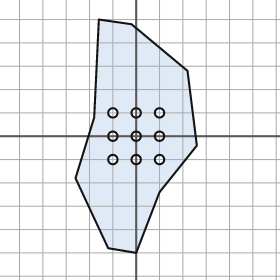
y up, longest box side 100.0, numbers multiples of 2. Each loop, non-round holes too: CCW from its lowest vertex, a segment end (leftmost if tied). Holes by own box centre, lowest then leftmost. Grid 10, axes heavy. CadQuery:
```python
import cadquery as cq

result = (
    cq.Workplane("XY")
    .moveTo(0.0, -50.0)
    .lineTo(10.0, -24.0)
    .lineTo(26.0, -4.0)
    .lineTo(22.0, 28.0)
    .lineTo(-2.0, 48.0)
    .lineTo(-16.0, 50.0)
    .lineTo(-18.0, 8.0)
    .lineTo(-26.0, -18.0)
    .lineTo(-12.0, -48.0)
    .close()
    .moveTo(-10.0, -10.0)
    .circle(2.0)
    .moveTo(0.0, -10.0)
    .circle(2.0)
    .moveTo(10.0, -10.0)
    .circle(2.0)
    .moveTo(-10.0, 0.0)
    .circle(2.0)
    .moveTo(0.0, 0.0)
    .circle(2.0)
    .moveTo(10.0, 0.0)
    .circle(2.0)
    .moveTo(-10.0, 10.0)
    .circle(2.0)
    .moveTo(0.0, 10.0)
    .circle(2.0)
    .moveTo(10.0, 10.0)
    .circle(2.0)
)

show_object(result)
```